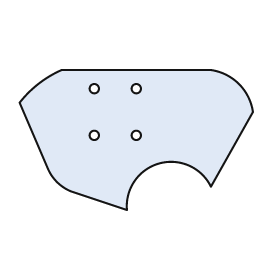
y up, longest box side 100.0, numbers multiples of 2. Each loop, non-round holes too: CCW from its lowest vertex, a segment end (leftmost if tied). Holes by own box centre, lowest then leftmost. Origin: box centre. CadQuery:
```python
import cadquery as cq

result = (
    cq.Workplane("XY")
    .moveTo(-4.0, -30.0)
    .threePointArc((10.0, -10.0), (32.0, -20.0))
    .lineTo(50.0, 12.0)
    .threePointArc((44.0, 24.0), (32.0, 30.0))
    .lineTo(-32.0, 30.0)
    .threePointArc((-42.0, 24.0), (-50.0, 16.0))
    .lineTo(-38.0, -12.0)
    .threePointArc((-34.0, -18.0), (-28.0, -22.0))
    .close()
    .moveTo(-18.0, 2.0)
    .circle(2.0)
    .moveTo(0.0, 2.0)
    .circle(2.0)
    .moveTo(-18.0, 22.0)
    .circle(2.0)
    .moveTo(0.0, 22.0)
    .circle(2.0)
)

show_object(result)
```